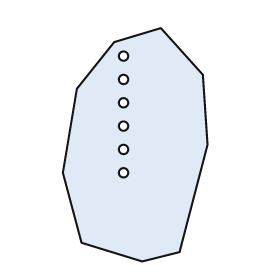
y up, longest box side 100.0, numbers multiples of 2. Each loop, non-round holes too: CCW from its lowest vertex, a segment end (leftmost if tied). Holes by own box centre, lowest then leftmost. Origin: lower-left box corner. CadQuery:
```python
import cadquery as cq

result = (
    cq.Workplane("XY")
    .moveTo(34.0, 0.0)
    .lineTo(50.0, 4.0)
    .lineTo(62.0, 50.0)
    .lineTo(60.0, 80.0)
    .lineTo(42.0, 100.0)
    .lineTo(22.0, 94.0)
    .lineTo(6.0, 74.0)
    .lineTo(0.0, 38.0)
    .lineTo(8.0, 8.0)
    .close()
    .moveTo(26.0, 38.0)
    .circle(2.0)
    .moveTo(26.0, 48.0)
    .circle(2.0)
    .moveTo(26.0, 58.0)
    .circle(2.0)
    .moveTo(26.0, 68.0)
    .circle(2.0)
    .moveTo(26.0, 78.0)
    .circle(2.0)
    .moveTo(26.0, 88.0)
    .circle(2.0)
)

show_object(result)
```